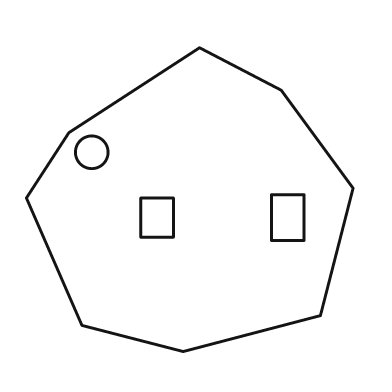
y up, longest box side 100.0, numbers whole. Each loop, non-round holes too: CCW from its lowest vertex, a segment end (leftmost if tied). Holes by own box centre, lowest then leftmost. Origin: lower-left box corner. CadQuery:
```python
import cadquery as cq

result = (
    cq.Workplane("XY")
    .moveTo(48.0, 0.0)
    .lineTo(90.0, 11.0)
    .lineTo(100.0, 50.0)
    .lineTo(78.0, 80.0)
    .lineTo(53.0, 93.0)
    .lineTo(13.0, 67.0)
    .lineTo(0.0, 47.0)
    .lineTo(17.0, 8.0)
    .close()
    .moveTo(35.0, 35.0)
    .lineTo(45.0, 35.0)
    .lineTo(45.0, 47.0)
    .lineTo(35.0, 47.0)
    .close()
    .moveTo(75.0, 34.0)
    .lineTo(85.0, 34.0)
    .lineTo(85.0, 48.0)
    .lineTo(75.0, 48.0)
    .close()
    .moveTo(20.0, 61.0)
    .circle(5.0)
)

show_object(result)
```